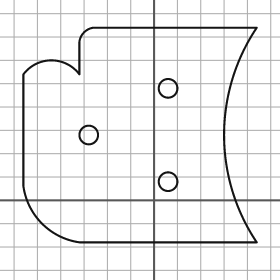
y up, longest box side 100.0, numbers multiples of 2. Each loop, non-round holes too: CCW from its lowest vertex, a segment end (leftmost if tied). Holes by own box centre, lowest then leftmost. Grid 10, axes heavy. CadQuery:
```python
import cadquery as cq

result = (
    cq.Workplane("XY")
    .moveTo(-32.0, -18.0)
    .lineTo(44.0, -18.0)
    .threePointArc((30.0, 28.0), (44.0, 74.0))
    .lineTo(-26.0, 74.0)
    .threePointArc((-30.0, 72.0), (-32.0, 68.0))
    .lineTo(-32.0, 54.0)
    .threePointArc((-44.0, 60.0), (-56.0, 54.0))
    .lineTo(-56.0, 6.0)
    .threePointArc((-48.0, -10.0), (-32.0, -18.0))
    .close()
    .moveTo(6.0, 8.0)
    .circle(4.0)
    .moveTo(-28.0, 28.0)
    .circle(4.0)
    .moveTo(6.0, 48.0)
    .circle(4.0)
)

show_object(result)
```